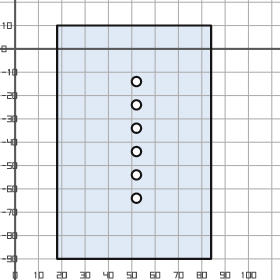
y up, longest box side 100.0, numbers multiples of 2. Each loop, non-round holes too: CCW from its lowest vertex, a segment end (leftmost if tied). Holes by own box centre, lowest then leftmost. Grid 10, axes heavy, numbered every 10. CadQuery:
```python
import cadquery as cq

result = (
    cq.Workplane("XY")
    .moveTo(18.0, -90.0)
    .lineTo(84.0, -90.0)
    .lineTo(84.0, 10.0)
    .lineTo(18.0, 10.0)
    .close()
    .moveTo(52.0, -64.0)
    .circle(2.0)
    .moveTo(52.0, -54.0)
    .circle(2.0)
    .moveTo(52.0, -44.0)
    .circle(2.0)
    .moveTo(52.0, -34.0)
    .circle(2.0)
    .moveTo(52.0, -24.0)
    .circle(2.0)
    .moveTo(52.0, -14.0)
    .circle(2.0)
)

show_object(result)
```